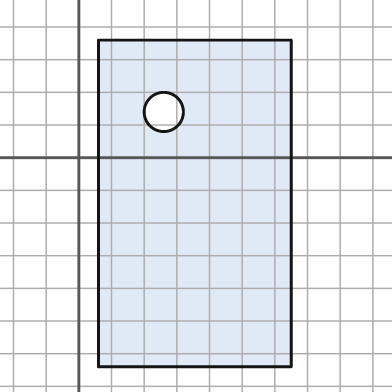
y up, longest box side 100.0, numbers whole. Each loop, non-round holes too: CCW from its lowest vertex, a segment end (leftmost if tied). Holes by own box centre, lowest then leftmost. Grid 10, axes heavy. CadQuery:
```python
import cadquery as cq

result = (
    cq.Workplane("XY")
    .moveTo(6.0, -64.0)
    .lineTo(65.0, -64.0)
    .lineTo(65.0, 36.0)
    .lineTo(6.0, 36.0)
    .close()
    .moveTo(26.0, 14.0)
    .circle(6.0)
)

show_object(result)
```